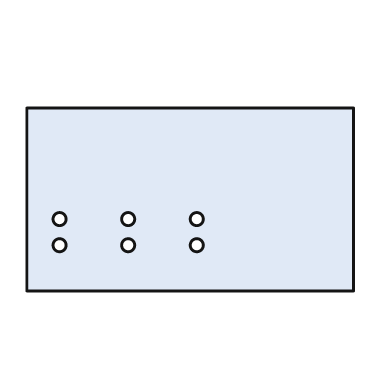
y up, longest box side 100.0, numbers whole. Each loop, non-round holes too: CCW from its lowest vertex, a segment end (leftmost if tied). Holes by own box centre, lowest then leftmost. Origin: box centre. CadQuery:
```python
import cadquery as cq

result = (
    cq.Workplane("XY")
    .moveTo(-50.0, -28.0)
    .lineTo(50.0, -28.0)
    .lineTo(50.0, 28.0)
    .lineTo(-50.0, 28.0)
    .close()
    .moveTo(-40.0, -14.0)
    .circle(2.0)
    .moveTo(-19.0, -14.0)
    .circle(2.0)
    .moveTo(2.0, -14.0)
    .circle(2.0)
    .moveTo(-40.0, -6.0)
    .circle(2.0)
    .moveTo(-19.0, -6.0)
    .circle(2.0)
    .moveTo(2.0, -6.0)
    .circle(2.0)
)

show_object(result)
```